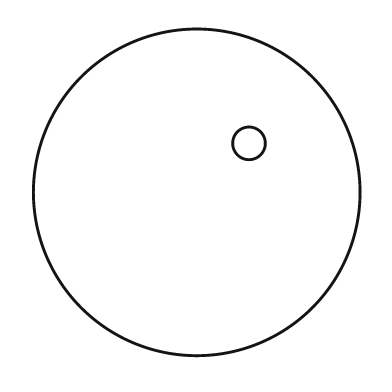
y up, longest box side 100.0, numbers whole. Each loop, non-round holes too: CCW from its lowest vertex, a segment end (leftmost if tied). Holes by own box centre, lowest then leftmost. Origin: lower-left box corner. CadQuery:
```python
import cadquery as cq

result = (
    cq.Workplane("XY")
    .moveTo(50.0, 50.0)
    .circle(50.0)
    .moveTo(66.0, 65.0)
    .circle(5.0)
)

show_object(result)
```